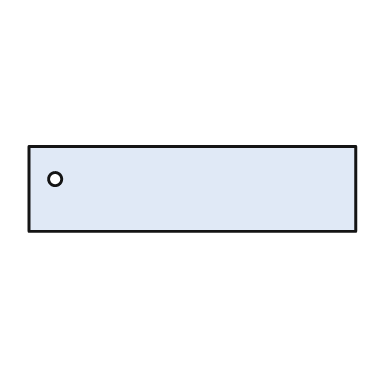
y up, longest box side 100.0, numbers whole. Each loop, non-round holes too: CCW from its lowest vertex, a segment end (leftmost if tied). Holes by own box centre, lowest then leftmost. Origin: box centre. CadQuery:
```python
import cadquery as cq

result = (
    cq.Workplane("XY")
    .moveTo(-50.0, -13.0)
    .lineTo(50.0, -13.0)
    .lineTo(50.0, 13.0)
    .lineTo(-50.0, 13.0)
    .close()
    .moveTo(-42.0, 3.0)
    .circle(2.0)
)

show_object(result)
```